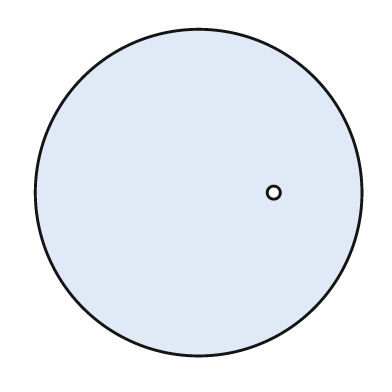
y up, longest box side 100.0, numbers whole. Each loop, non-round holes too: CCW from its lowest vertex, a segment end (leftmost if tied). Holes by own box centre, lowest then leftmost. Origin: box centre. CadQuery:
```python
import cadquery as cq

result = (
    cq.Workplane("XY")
    .moveTo(0.0, 0.0)
    .circle(50.0)
    .moveTo(23.0, 0.0)
    .circle(2.0)
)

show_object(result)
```